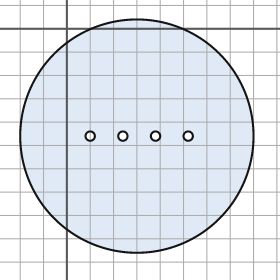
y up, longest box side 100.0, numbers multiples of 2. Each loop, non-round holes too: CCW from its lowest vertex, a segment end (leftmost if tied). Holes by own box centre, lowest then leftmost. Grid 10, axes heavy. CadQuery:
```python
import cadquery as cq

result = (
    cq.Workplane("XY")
    .moveTo(30.0, -46.0)
    .circle(50.0)
    .moveTo(10.0, -46.0)
    .circle(2.0)
    .moveTo(24.0, -46.0)
    .circle(2.0)
    .moveTo(38.0, -46.0)
    .circle(2.0)
    .moveTo(52.0, -46.0)
    .circle(2.0)
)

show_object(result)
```